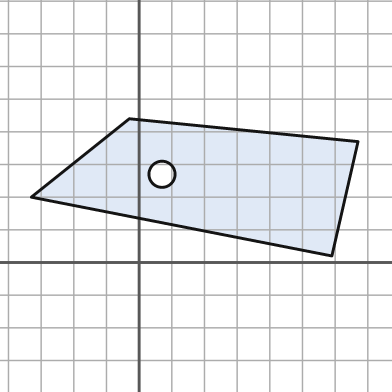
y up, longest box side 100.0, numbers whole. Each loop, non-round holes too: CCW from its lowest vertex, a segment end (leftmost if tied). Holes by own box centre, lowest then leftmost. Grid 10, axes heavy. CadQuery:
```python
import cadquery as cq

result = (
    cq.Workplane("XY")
    .moveTo(59.0, 2.0)
    .lineTo(67.0, 37.0)
    .lineTo(-3.0, 44.0)
    .lineTo(-33.0, 20.0)
    .close()
    .moveTo(7.0, 27.0)
    .circle(4.0)
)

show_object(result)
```